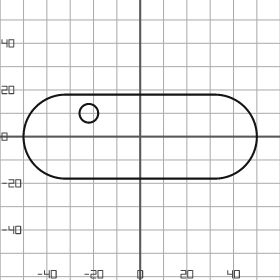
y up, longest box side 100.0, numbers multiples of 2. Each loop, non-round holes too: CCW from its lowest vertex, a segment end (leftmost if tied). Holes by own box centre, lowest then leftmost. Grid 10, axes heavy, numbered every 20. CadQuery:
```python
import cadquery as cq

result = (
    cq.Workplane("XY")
    .moveTo(-32.0, -18.0)
    .lineTo(32.0, -18.0)
    .threePointArc((50.0, 0.0), (32.0, 18.0))
    .lineTo(-32.0, 18.0)
    .threePointArc((-50.0, 0.0), (-32.0, -18.0))
    .close()
    .moveTo(-22.0, 10.0)
    .circle(4.0)
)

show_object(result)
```